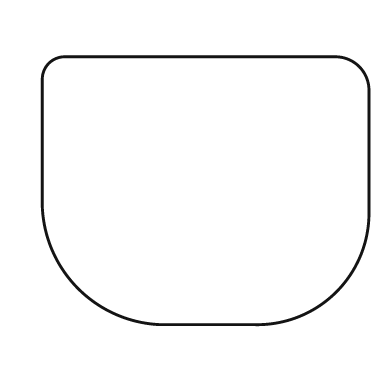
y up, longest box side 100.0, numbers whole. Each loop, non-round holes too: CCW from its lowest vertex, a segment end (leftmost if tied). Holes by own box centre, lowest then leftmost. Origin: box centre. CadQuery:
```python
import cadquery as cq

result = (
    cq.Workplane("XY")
    .moveTo(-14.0, -41.0)
    .lineTo(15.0, -41.0)
    .threePointArc((40.0, -31.0), (50.0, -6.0))
    .lineTo(50.0, 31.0)
    .threePointArc((47.0, 38.0), (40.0, 41.0))
    .lineTo(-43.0, 41.0)
    .threePointArc((-48.0, 39.0), (-50.0, 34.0))
    .lineTo(-50.0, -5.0)
    .threePointArc((-39.0, -30.0), (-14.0, -41.0))
    .close()
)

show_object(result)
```